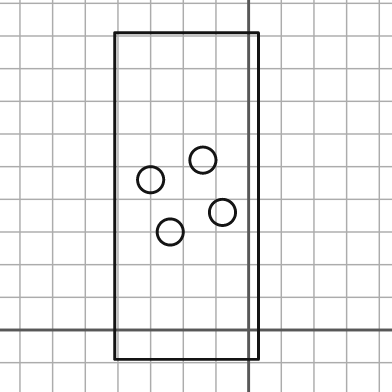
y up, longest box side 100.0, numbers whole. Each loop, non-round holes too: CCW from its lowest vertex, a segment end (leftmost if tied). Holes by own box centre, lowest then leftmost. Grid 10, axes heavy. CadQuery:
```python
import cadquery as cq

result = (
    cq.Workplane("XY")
    .moveTo(-41.0, -9.0)
    .lineTo(3.0, -9.0)
    .lineTo(3.0, 91.0)
    .lineTo(-41.0, 91.0)
    .close()
    .moveTo(-24.0, 30.0)
    .circle(4.0)
    .moveTo(-8.0, 36.0)
    .circle(4.0)
    .moveTo(-30.0, 46.0)
    .circle(4.0)
    .moveTo(-14.0, 52.0)
    .circle(4.0)
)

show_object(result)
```